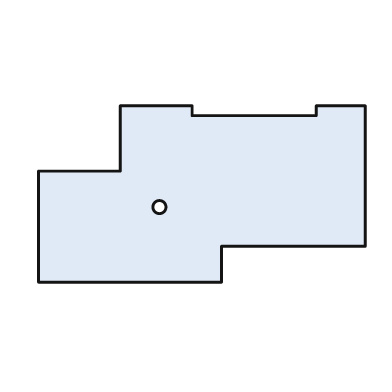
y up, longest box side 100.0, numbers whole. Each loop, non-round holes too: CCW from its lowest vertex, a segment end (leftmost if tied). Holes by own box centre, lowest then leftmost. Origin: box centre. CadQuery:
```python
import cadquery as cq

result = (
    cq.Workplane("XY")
    .moveTo(-50.0, -27.0)
    .lineTo(6.0, -27.0)
    .lineTo(6.0, -16.0)
    .lineTo(50.0, -16.0)
    .lineTo(50.0, 27.0)
    .lineTo(35.0, 27.0)
    .lineTo(35.0, 24.0)
    .lineTo(-3.0, 24.0)
    .lineTo(-3.0, 27.0)
    .lineTo(-25.0, 27.0)
    .lineTo(-25.0, 7.0)
    .lineTo(-50.0, 7.0)
    .close()
    .moveTo(-13.0, -4.0)
    .circle(2.0)
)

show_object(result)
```